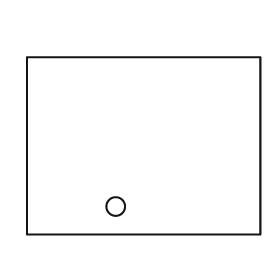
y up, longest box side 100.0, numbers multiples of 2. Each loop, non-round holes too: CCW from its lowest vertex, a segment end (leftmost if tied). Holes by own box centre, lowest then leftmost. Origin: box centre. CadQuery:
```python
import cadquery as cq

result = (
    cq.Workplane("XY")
    .moveTo(-50.0, -38.0)
    .lineTo(50.0, -38.0)
    .lineTo(50.0, 38.0)
    .lineTo(-50.0, 38.0)
    .close()
    .moveTo(-12.0, -26.0)
    .circle(4.0)
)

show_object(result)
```